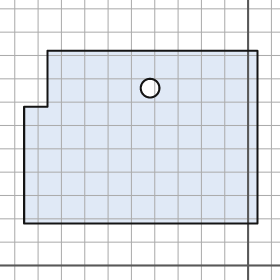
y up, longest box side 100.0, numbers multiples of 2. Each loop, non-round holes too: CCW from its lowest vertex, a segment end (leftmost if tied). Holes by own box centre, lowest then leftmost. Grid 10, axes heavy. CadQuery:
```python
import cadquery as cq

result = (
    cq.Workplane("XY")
    .moveTo(-96.0, 18.0)
    .lineTo(4.0, 18.0)
    .lineTo(4.0, 92.0)
    .lineTo(-86.0, 92.0)
    .lineTo(-86.0, 68.0)
    .lineTo(-96.0, 68.0)
    .close()
    .moveTo(-42.0, 76.0)
    .circle(4.0)
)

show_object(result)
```